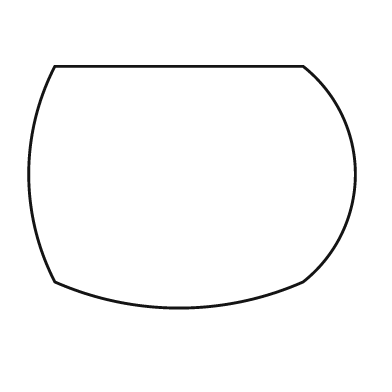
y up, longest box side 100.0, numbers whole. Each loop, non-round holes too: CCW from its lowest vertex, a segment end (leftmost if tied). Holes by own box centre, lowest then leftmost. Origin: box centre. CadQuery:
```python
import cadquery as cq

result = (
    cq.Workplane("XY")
    .moveTo(-42.0, -29.0)
    .threePointArc((-4.0, -37.0), (34.0, -29.0))
    .threePointArc((50.0, 4.0), (34.0, 37.0))
    .lineTo(-42.0, 37.0)
    .threePointArc((-50.0, 4.0), (-42.0, -29.0))
    .close()
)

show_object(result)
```